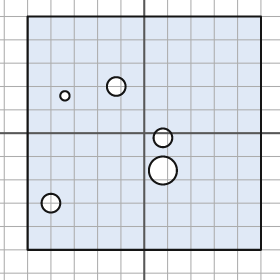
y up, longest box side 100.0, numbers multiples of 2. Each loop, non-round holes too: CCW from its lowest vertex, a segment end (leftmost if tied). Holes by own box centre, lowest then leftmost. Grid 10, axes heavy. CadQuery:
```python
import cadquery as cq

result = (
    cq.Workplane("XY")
    .moveTo(-50.0, -50.0)
    .lineTo(50.0, -50.0)
    .lineTo(50.0, 50.0)
    .lineTo(-50.0, 50.0)
    .close()
    .moveTo(-40.0, -30.0)
    .circle(4.0)
    .moveTo(8.0, -16.0)
    .circle(6.0)
    .moveTo(8.0, -2.0)
    .circle(4.0)
    .moveTo(-34.0, 16.0)
    .circle(2.0)
    .moveTo(-12.0, 20.0)
    .circle(4.0)
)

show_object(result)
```